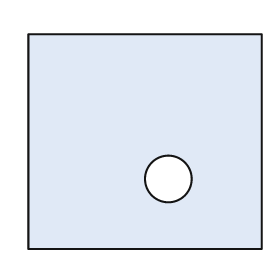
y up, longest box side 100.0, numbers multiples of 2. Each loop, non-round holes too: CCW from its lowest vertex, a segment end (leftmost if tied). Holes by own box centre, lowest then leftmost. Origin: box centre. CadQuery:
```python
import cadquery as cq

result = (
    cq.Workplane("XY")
    .moveTo(-50.0, -46.0)
    .lineTo(50.0, -46.0)
    .lineTo(50.0, 46.0)
    .lineTo(-50.0, 46.0)
    .close()
    .moveTo(10.0, -16.0)
    .circle(10.0)
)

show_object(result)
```